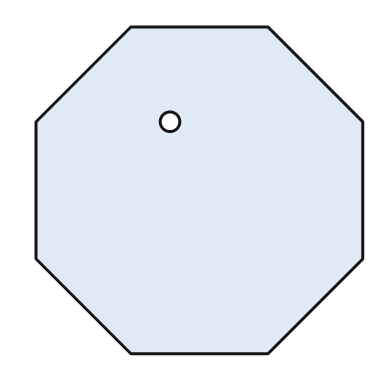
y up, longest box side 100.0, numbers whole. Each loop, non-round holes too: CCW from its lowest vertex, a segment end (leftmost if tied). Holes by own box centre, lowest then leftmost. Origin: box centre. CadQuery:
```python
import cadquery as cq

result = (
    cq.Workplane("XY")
    .moveTo(-21.0, -50.0)
    .lineTo(21.0, -50.0)
    .lineTo(50.0, -21.0)
    .lineTo(50.0, 21.0)
    .lineTo(21.0, 50.0)
    .lineTo(-21.0, 50.0)
    .lineTo(-50.0, 21.0)
    .lineTo(-50.0, -21.0)
    .close()
    .moveTo(-9.0, 21.0)
    .circle(3.0)
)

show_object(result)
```